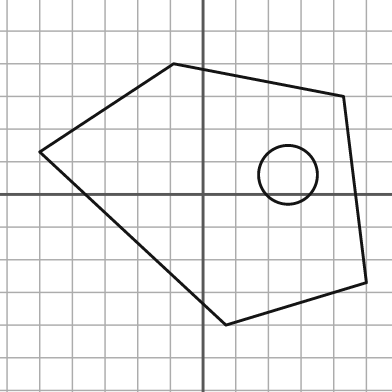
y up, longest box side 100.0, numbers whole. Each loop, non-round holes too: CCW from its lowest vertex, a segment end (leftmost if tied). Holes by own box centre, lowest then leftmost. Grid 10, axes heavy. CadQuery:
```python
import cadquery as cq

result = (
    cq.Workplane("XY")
    .moveTo(7.0, -40.0)
    .lineTo(50.0, -27.0)
    .lineTo(43.0, 30.0)
    .lineTo(-9.0, 40.0)
    .lineTo(-50.0, 13.0)
    .close()
    .moveTo(26.0, 6.0)
    .circle(9.0)
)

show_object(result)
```